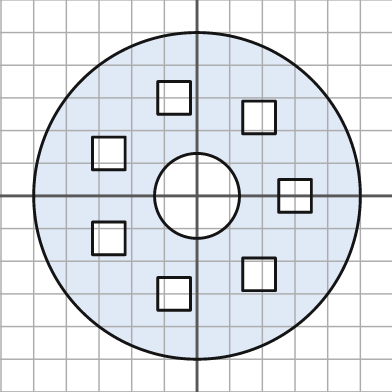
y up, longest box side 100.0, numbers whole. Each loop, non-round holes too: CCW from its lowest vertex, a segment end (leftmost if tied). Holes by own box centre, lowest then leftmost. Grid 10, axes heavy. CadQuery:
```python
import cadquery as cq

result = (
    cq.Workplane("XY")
    .moveTo(0.0, 0.0)
    .circle(50.0)
    .moveTo(-12.0, -35.0)
    .lineTo(-2.0, -35.0)
    .lineTo(-2.0, -25.0)
    .lineTo(-12.0, -25.0)
    .close()
    .moveTo(14.0, -29.0)
    .lineTo(24.0, -29.0)
    .lineTo(24.0, -19.0)
    .lineTo(14.0, -19.0)
    .close()
    .moveTo(-32.0, -18.0)
    .lineTo(-22.0, -18.0)
    .lineTo(-22.0, -8.0)
    .lineTo(-32.0, -8.0)
    .close()
    .moveTo(0.0, 0.0)
    .circle(13.0)
    .moveTo(25.0, -5.0)
    .lineTo(35.0, -5.0)
    .lineTo(35.0, 5.0)
    .lineTo(25.0, 5.0)
    .close()
    .moveTo(-32.0, 8.0)
    .lineTo(-22.0, 8.0)
    .lineTo(-22.0, 18.0)
    .lineTo(-32.0, 18.0)
    .close()
    .moveTo(14.0, 19.0)
    .lineTo(24.0, 19.0)
    .lineTo(24.0, 29.0)
    .lineTo(14.0, 29.0)
    .close()
    .moveTo(-12.0, 25.0)
    .lineTo(-2.0, 25.0)
    .lineTo(-2.0, 35.0)
    .lineTo(-12.0, 35.0)
    .close()
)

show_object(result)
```